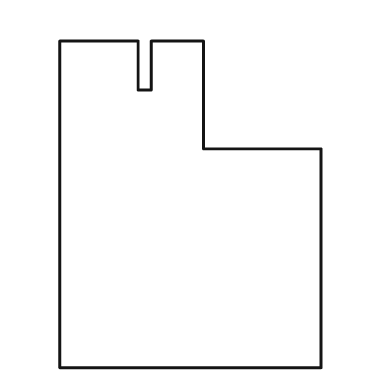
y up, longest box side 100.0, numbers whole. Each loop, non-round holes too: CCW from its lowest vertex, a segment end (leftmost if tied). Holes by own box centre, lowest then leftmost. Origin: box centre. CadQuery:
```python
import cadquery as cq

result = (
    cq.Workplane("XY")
    .moveTo(-40.0, -50.0)
    .lineTo(40.0, -50.0)
    .lineTo(40.0, 17.0)
    .lineTo(4.0, 17.0)
    .lineTo(4.0, 50.0)
    .lineTo(-12.0, 50.0)
    .lineTo(-12.0, 35.0)
    .lineTo(-16.0, 35.0)
    .lineTo(-16.0, 50.0)
    .lineTo(-40.0, 50.0)
    .close()
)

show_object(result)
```